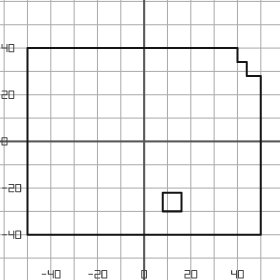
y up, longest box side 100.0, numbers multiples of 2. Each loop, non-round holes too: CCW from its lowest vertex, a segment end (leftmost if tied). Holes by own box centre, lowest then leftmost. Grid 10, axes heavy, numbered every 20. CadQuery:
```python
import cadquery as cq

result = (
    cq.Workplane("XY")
    .moveTo(-50.0, -40.0)
    .lineTo(50.0, -40.0)
    .lineTo(50.0, 28.0)
    .lineTo(44.0, 28.0)
    .lineTo(44.0, 34.0)
    .lineTo(40.0, 34.0)
    .lineTo(40.0, 40.0)
    .lineTo(-50.0, 40.0)
    .close()
    .moveTo(8.0, -30.0)
    .lineTo(16.0, -30.0)
    .lineTo(16.0, -22.0)
    .lineTo(8.0, -22.0)
    .close()
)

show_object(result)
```